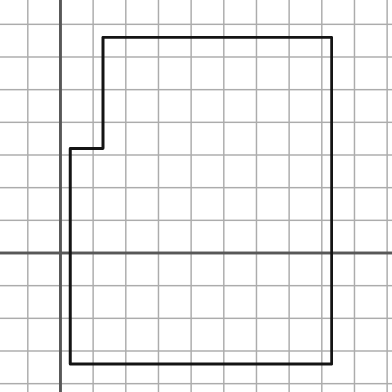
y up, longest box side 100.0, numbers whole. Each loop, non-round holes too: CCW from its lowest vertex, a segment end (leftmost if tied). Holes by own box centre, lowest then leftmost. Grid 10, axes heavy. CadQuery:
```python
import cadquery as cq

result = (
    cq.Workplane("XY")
    .moveTo(3.0, -34.0)
    .lineTo(83.0, -34.0)
    .lineTo(83.0, 66.0)
    .lineTo(13.0, 66.0)
    .lineTo(13.0, 32.0)
    .lineTo(3.0, 32.0)
    .close()
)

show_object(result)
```